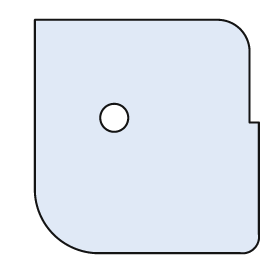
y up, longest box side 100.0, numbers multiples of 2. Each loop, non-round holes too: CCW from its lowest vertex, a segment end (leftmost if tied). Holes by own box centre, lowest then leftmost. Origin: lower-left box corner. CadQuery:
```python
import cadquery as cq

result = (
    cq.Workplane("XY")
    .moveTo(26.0, 0.0)
    .lineTo(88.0, 0.0)
    .threePointArc((94.0, 2.0), (96.0, 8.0))
    .lineTo(96.0, 56.0)
    .lineTo(92.0, 56.0)
    .lineTo(92.0, 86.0)
    .threePointArc((88.0, 96.0), (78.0, 100.0))
    .lineTo(0.0, 100.0)
    .lineTo(0.0, 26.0)
    .threePointArc((8.0, 8.0), (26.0, 0.0))
    .close()
    .moveTo(34.0, 58.0)
    .circle(6.0)
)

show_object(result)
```